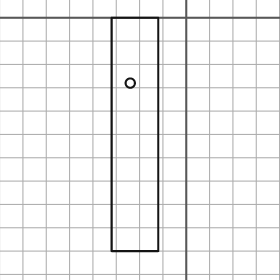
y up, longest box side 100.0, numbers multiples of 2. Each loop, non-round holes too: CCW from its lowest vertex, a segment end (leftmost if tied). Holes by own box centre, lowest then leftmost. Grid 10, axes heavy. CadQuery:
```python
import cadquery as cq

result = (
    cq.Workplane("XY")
    .moveTo(-32.0, -100.0)
    .lineTo(-12.0, -100.0)
    .lineTo(-12.0, 0.0)
    .lineTo(-32.0, 0.0)
    .close()
    .moveTo(-24.0, -28.0)
    .circle(2.0)
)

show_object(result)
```